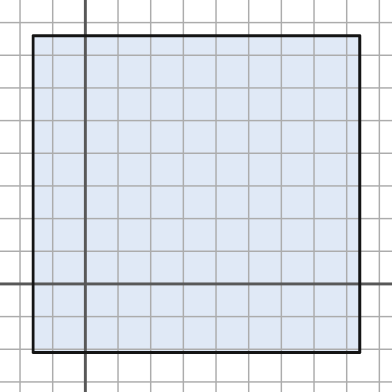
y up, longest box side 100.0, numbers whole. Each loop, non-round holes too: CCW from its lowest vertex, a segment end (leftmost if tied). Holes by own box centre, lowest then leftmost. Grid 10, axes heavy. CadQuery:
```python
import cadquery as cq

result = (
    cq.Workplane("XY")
    .moveTo(-16.0, -21.0)
    .lineTo(84.0, -21.0)
    .lineTo(84.0, 76.0)
    .lineTo(-16.0, 76.0)
    .close()
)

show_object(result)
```